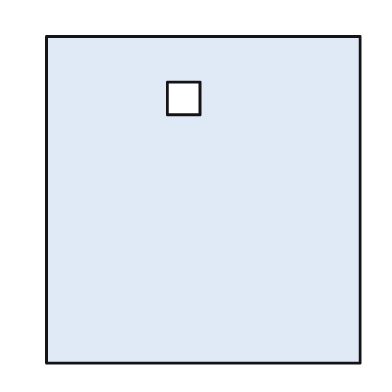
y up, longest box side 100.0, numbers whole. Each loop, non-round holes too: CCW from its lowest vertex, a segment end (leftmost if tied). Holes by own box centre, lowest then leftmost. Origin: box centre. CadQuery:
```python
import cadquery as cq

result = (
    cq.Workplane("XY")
    .moveTo(-48.0, -50.0)
    .lineTo(48.0, -50.0)
    .lineTo(48.0, 50.0)
    .lineTo(-48.0, 50.0)
    .close()
    .moveTo(-11.0, 26.0)
    .lineTo(-1.0, 26.0)
    .lineTo(-1.0, 36.0)
    .lineTo(-11.0, 36.0)
    .close()
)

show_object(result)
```